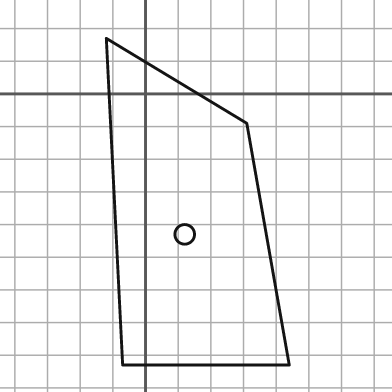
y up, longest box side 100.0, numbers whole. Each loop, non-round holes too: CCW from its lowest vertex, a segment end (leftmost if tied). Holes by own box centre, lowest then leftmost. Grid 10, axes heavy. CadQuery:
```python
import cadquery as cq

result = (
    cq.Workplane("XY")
    .moveTo(-7.0, -83.0)
    .lineTo(44.0, -83.0)
    .lineTo(31.0, -9.0)
    .lineTo(-12.0, 17.0)
    .close()
    .moveTo(12.0, -43.0)
    .circle(3.0)
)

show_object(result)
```